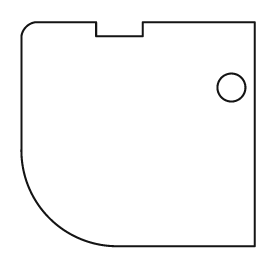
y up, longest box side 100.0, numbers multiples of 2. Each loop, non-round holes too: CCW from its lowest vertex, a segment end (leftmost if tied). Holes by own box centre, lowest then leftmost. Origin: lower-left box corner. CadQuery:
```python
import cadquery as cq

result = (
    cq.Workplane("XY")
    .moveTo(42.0, 0.0)
    .lineTo(100.0, 0.0)
    .lineTo(100.0, 96.0)
    .lineTo(52.0, 96.0)
    .lineTo(52.0, 90.0)
    .lineTo(32.0, 90.0)
    .lineTo(32.0, 96.0)
    .lineTo(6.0, 96.0)
    .threePointArc((2.0, 94.0), (0.0, 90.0))
    .lineTo(0.0, 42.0)
    .threePointArc((12.0, 12.0), (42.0, 0.0))
    .close()
    .moveTo(90.0, 68.0)
    .circle(6.0)
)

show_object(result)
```